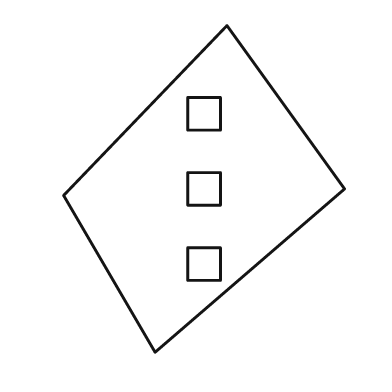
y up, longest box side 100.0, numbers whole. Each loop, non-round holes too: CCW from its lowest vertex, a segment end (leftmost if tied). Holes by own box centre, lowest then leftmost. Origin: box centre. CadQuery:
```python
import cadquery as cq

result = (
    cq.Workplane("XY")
    .moveTo(-15.0, -50.0)
    .lineTo(43.0, 0.0)
    .lineTo(7.0, 50.0)
    .lineTo(-43.0, -2.0)
    .close()
    .moveTo(-5.0, -28.0)
    .lineTo(5.0, -28.0)
    .lineTo(5.0, -18.0)
    .lineTo(-5.0, -18.0)
    .close()
    .moveTo(-5.0, -5.0)
    .lineTo(5.0, -5.0)
    .lineTo(5.0, 5.0)
    .lineTo(-5.0, 5.0)
    .close()
    .moveTo(-5.0, 18.0)
    .lineTo(5.0, 18.0)
    .lineTo(5.0, 28.0)
    .lineTo(-5.0, 28.0)
    .close()
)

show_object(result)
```